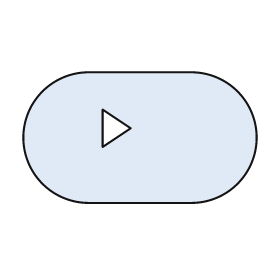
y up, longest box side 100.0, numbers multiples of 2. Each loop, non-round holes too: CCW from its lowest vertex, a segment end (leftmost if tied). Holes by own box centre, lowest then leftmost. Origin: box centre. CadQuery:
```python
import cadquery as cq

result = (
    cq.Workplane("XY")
    .moveTo(-22.0, -28.0)
    .lineTo(22.0, -28.0)
    .threePointArc((50.0, 0.0), (22.0, 28.0))
    .lineTo(-22.0, 28.0)
    .threePointArc((-50.0, 0.0), (-22.0, -28.0))
    .close()
    .moveTo(-16.0, -4.0)
    .lineTo(-4.0, 4.0)
    .lineTo(-16.0, 12.0)
    .close()
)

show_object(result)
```